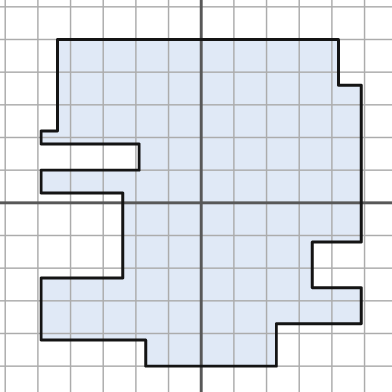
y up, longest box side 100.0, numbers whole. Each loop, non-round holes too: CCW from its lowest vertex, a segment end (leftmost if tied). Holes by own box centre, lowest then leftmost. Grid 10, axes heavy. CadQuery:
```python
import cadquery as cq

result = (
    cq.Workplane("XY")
    .moveTo(-17.0, -50.0)
    .lineTo(23.0, -50.0)
    .lineTo(23.0, -37.0)
    .lineTo(49.0, -37.0)
    .lineTo(49.0, -26.0)
    .lineTo(34.0, -26.0)
    .lineTo(34.0, -12.0)
    .lineTo(49.0, -12.0)
    .lineTo(49.0, 36.0)
    .lineTo(42.0, 36.0)
    .lineTo(42.0, 50.0)
    .lineTo(-44.0, 50.0)
    .lineTo(-44.0, 22.0)
    .lineTo(-49.0, 22.0)
    .lineTo(-49.0, 18.0)
    .lineTo(-19.0, 18.0)
    .lineTo(-19.0, 10.0)
    .lineTo(-49.0, 10.0)
    .lineTo(-49.0, 3.0)
    .lineTo(-24.0, 3.0)
    .lineTo(-24.0, -23.0)
    .lineTo(-49.0, -23.0)
    .lineTo(-49.0, -42.0)
    .lineTo(-17.0, -42.0)
    .close()
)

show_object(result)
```